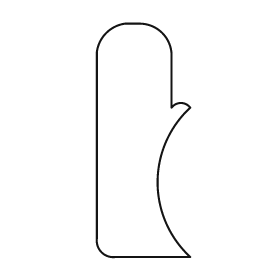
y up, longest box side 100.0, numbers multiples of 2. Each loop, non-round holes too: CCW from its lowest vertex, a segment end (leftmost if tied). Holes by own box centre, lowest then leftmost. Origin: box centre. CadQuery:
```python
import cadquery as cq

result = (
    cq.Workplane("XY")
    .moveTo(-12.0, -50.0)
    .lineTo(20.0, -50.0)
    .threePointArc((6.0, -18.0), (20.0, 14.0))
    .threePointArc((16.0, 16.0), (12.0, 14.0))
    .lineTo(12.0, 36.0)
    .threePointArc((8.0, 46.0), (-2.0, 50.0))
    .lineTo(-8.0, 50.0)
    .threePointArc((-16.0, 46.0), (-20.0, 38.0))
    .lineTo(-20.0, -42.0)
    .threePointArc((-18.0, -48.0), (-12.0, -50.0))
    .close()
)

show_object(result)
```